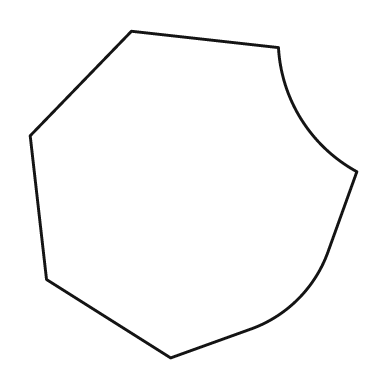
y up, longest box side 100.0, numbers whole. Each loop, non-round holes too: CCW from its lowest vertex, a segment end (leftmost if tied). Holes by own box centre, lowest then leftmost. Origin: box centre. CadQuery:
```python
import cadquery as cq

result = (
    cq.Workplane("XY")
    .moveTo(-7.0, -50.0)
    .lineTo(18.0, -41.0)
    .threePointArc((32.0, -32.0), (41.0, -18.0))
    .lineTo(50.0, 7.0)
    .threePointArc((33.0, 23.0), (26.0, 45.0))
    .lineTo(-19.0, 50.0)
    .lineTo(-50.0, 18.0)
    .lineTo(-45.0, -26.0)
    .close()
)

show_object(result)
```